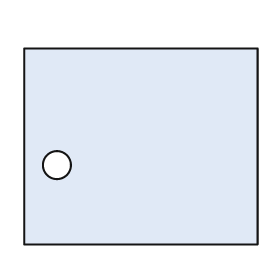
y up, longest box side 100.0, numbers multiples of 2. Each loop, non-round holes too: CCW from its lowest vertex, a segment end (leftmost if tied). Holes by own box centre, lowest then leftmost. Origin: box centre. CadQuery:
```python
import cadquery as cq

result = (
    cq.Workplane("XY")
    .moveTo(-50.0, -42.0)
    .lineTo(50.0, -42.0)
    .lineTo(50.0, 42.0)
    .lineTo(-50.0, 42.0)
    .close()
    .moveTo(-36.0, -8.0)
    .circle(6.0)
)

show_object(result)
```